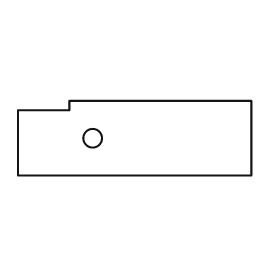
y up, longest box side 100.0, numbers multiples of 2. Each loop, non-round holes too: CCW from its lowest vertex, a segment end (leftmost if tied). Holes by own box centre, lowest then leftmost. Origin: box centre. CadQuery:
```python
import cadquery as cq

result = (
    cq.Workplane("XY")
    .moveTo(-50.0, -16.0)
    .lineTo(50.0, -16.0)
    .lineTo(50.0, 16.0)
    .lineTo(-28.0, 16.0)
    .lineTo(-28.0, 12.0)
    .lineTo(-50.0, 12.0)
    .close()
    .moveTo(-18.0, 0.0)
    .circle(4.0)
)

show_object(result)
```